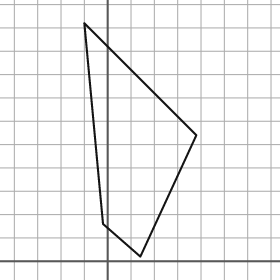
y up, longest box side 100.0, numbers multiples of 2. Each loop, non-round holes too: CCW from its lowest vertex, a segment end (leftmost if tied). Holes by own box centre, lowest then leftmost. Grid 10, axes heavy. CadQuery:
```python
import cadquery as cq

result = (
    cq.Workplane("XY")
    .moveTo(14.0, 2.0)
    .lineTo(38.0, 54.0)
    .lineTo(-10.0, 102.0)
    .lineTo(-2.0, 16.0)
    .close()
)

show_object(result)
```